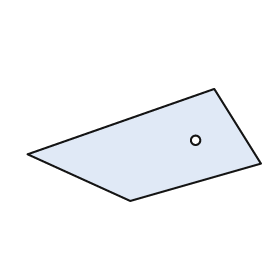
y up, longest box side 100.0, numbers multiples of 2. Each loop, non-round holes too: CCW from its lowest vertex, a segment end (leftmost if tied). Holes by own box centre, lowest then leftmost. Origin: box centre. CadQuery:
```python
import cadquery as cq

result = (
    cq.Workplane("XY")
    .moveTo(-6.0, -24.0)
    .lineTo(50.0, -8.0)
    .lineTo(30.0, 24.0)
    .lineTo(-50.0, -4.0)
    .close()
    .moveTo(22.0, 2.0)
    .circle(2.0)
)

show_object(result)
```